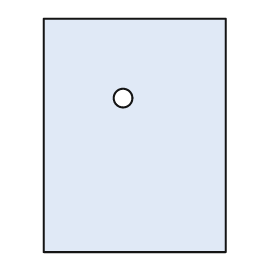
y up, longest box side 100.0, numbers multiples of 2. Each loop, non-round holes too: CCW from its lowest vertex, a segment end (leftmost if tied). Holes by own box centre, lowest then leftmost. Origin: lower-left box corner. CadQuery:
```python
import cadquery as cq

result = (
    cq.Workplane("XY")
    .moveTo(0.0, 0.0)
    .lineTo(78.0, 0.0)
    .lineTo(78.0, 100.0)
    .lineTo(0.0, 100.0)
    .close()
    .moveTo(34.0, 66.0)
    .circle(4.0)
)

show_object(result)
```